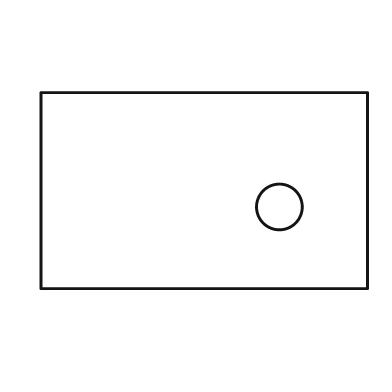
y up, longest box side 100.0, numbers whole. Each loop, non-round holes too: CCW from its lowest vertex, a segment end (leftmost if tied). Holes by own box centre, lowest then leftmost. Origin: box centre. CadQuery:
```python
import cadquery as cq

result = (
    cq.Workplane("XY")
    .moveTo(-50.0, -30.0)
    .lineTo(50.0, -30.0)
    .lineTo(50.0, 30.0)
    .lineTo(-50.0, 30.0)
    .close()
    .moveTo(23.0, -5.0)
    .circle(7.0)
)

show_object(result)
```